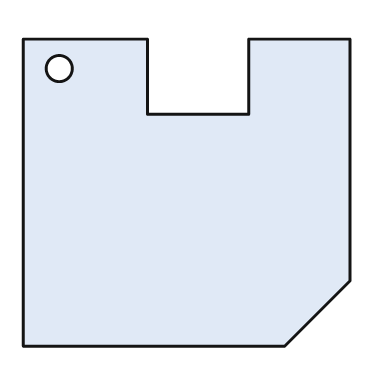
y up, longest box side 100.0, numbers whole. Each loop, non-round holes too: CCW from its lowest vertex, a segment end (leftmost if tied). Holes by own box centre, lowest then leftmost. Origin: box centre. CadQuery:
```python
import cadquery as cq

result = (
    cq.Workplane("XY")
    .moveTo(-50.0, -47.0)
    .lineTo(30.0, -47.0)
    .lineTo(50.0, -27.0)
    .lineTo(50.0, 47.0)
    .lineTo(19.0, 47.0)
    .lineTo(19.0, 24.0)
    .lineTo(-12.0, 24.0)
    .lineTo(-12.0, 47.0)
    .lineTo(-50.0, 47.0)
    .close()
    .moveTo(-39.0, 38.0)
    .circle(4.0)
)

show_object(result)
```